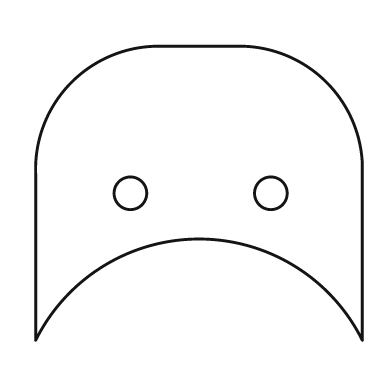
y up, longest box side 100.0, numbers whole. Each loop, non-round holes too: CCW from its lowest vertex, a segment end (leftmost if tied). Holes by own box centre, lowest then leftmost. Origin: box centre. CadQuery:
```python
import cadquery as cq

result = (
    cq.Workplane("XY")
    .moveTo(-50.0, -45.0)
    .threePointArc((0.0, -14.0), (50.0, -45.0))
    .lineTo(50.0, 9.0)
    .threePointArc((39.0, 34.0), (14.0, 45.0))
    .lineTo(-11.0, 45.0)
    .threePointArc((-39.0, 34.0), (-50.0, 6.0))
    .close()
    .moveTo(-21.0, 0.0)
    .circle(5.0)
    .moveTo(22.0, 0.0)
    .circle(5.0)
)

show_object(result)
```